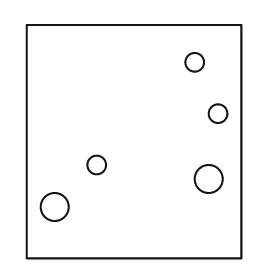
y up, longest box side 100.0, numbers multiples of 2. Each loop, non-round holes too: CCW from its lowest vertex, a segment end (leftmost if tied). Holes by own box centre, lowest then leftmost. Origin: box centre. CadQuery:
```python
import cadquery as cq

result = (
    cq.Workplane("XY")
    .moveTo(-46.0, -50.0)
    .lineTo(46.0, -50.0)
    .lineTo(46.0, 50.0)
    .lineTo(-46.0, 50.0)
    .close()
    .moveTo(-34.0, -28.0)
    .circle(6.0)
    .moveTo(32.0, -16.0)
    .circle(6.0)
    .moveTo(-16.0, -10.0)
    .circle(4.0)
    .moveTo(36.0, 12.0)
    .circle(4.0)
    .moveTo(26.0, 34.0)
    .circle(4.0)
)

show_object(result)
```